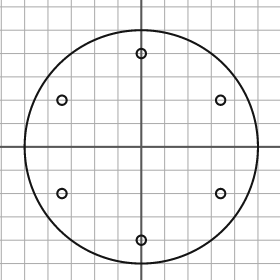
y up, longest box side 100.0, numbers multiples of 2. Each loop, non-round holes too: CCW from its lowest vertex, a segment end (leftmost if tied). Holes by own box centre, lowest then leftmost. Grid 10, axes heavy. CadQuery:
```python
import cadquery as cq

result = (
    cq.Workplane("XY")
    .moveTo(0.0, 0.0)
    .circle(50.0)
    .moveTo(0.0, -40.0)
    .circle(2.0)
    .moveTo(-34.0, -20.0)
    .circle(2.0)
    .moveTo(34.0, -20.0)
    .circle(2.0)
    .moveTo(-34.0, 20.0)
    .circle(2.0)
    .moveTo(34.0, 20.0)
    .circle(2.0)
    .moveTo(0.0, 40.0)
    .circle(2.0)
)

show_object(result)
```